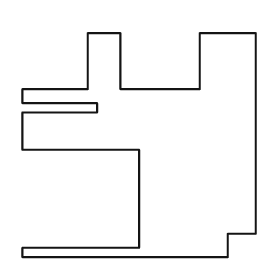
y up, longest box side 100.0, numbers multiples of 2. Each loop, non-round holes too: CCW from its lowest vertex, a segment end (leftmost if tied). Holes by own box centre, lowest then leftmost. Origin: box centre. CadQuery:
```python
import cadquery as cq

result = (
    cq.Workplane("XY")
    .moveTo(-50.0, -48.0)
    .lineTo(38.0, -48.0)
    .lineTo(38.0, -38.0)
    .lineTo(50.0, -38.0)
    .lineTo(50.0, 48.0)
    .lineTo(26.0, 48.0)
    .lineTo(26.0, 24.0)
    .lineTo(-8.0, 24.0)
    .lineTo(-8.0, 48.0)
    .lineTo(-22.0, 48.0)
    .lineTo(-22.0, 24.0)
    .lineTo(-50.0, 24.0)
    .lineTo(-50.0, 18.0)
    .lineTo(-18.0, 18.0)
    .lineTo(-18.0, 14.0)
    .lineTo(-50.0, 14.0)
    .lineTo(-50.0, -2.0)
    .lineTo(0.0, -2.0)
    .lineTo(0.0, -44.0)
    .lineTo(-50.0, -44.0)
    .close()
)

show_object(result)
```